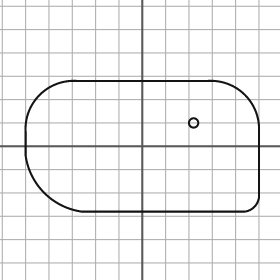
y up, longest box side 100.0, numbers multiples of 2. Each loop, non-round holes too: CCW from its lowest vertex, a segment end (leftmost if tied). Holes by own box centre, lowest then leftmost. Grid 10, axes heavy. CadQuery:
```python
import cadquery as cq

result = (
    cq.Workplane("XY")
    .moveTo(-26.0, -28.0)
    .lineTo(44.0, -28.0)
    .threePointArc((48.0, -26.0), (50.0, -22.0))
    .lineTo(50.0, 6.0)
    .threePointArc((44.0, 22.0), (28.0, 28.0))
    .lineTo(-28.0, 28.0)
    .threePointArc((-44.0, 22.0), (-50.0, 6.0))
    .lineTo(-50.0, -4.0)
    .threePointArc((-42.0, -20.0), (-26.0, -28.0))
    .close()
    .moveTo(22.0, 10.0)
    .circle(2.0)
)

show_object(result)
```